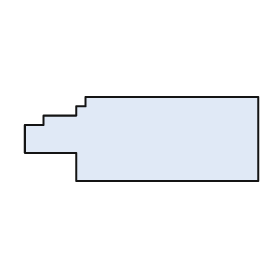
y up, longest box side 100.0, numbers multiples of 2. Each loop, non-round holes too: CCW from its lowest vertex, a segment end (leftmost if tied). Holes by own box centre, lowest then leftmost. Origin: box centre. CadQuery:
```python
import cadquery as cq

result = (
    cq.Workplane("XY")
    .moveTo(-28.0, -18.0)
    .lineTo(50.0, -18.0)
    .lineTo(50.0, 18.0)
    .lineTo(-24.0, 18.0)
    .lineTo(-24.0, 14.0)
    .lineTo(-28.0, 14.0)
    .lineTo(-28.0, 10.0)
    .lineTo(-42.0, 10.0)
    .lineTo(-42.0, 6.0)
    .lineTo(-50.0, 6.0)
    .lineTo(-50.0, -6.0)
    .lineTo(-28.0, -6.0)
    .close()
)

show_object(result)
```